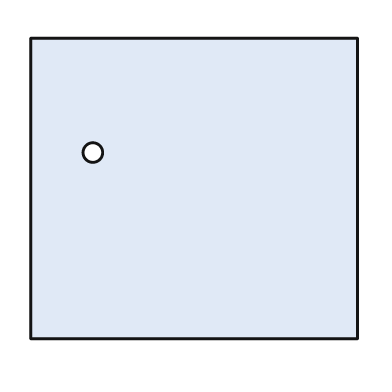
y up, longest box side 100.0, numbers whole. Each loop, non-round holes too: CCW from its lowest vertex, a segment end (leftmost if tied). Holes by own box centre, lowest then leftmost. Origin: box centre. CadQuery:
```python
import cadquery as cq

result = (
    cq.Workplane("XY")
    .moveTo(-50.0, -46.0)
    .lineTo(50.0, -46.0)
    .lineTo(50.0, 46.0)
    .lineTo(-50.0, 46.0)
    .close()
    .moveTo(-31.0, 11.0)
    .circle(3.0)
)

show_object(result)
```